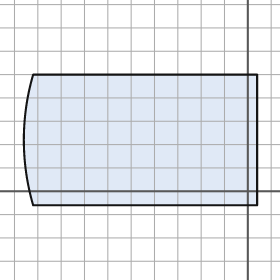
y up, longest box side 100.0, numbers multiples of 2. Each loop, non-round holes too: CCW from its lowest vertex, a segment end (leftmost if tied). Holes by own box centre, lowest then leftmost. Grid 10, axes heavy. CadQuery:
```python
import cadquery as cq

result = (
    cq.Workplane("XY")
    .moveTo(-92.0, -6.0)
    .lineTo(4.0, -6.0)
    .lineTo(4.0, 50.0)
    .lineTo(-92.0, 50.0)
    .threePointArc((-96.0, 22.0), (-92.0, -6.0))
    .close()
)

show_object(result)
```